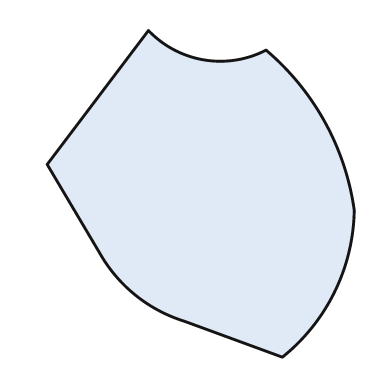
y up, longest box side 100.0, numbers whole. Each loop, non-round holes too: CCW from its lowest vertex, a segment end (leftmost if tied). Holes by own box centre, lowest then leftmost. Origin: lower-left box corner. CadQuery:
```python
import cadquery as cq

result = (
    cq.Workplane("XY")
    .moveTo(72.0, 0.0)
    .threePointArc((88.0, 20.0), (94.0, 45.0))
    .threePointArc((85.0, 72.0), (67.0, 94.0))
    .threePointArc((48.0, 91.0), (31.0, 100.0))
    .lineTo(0.0, 59.0)
    .lineTo(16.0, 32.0)
    .threePointArc((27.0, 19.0), (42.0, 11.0))
    .close()
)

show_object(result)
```